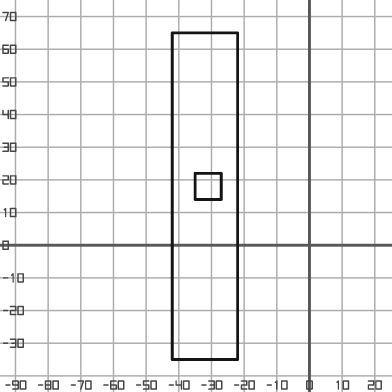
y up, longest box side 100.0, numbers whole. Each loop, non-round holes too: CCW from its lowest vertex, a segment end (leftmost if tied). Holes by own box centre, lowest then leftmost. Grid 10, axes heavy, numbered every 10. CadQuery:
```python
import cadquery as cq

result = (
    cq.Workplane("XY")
    .moveTo(-42.0, -35.0)
    .lineTo(-22.0, -35.0)
    .lineTo(-22.0, 65.0)
    .lineTo(-42.0, 65.0)
    .close()
    .moveTo(-35.0, 14.0)
    .lineTo(-27.0, 14.0)
    .lineTo(-27.0, 22.0)
    .lineTo(-35.0, 22.0)
    .close()
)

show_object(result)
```